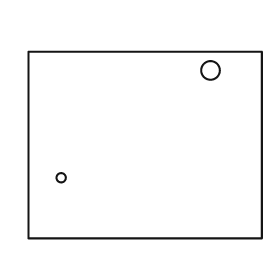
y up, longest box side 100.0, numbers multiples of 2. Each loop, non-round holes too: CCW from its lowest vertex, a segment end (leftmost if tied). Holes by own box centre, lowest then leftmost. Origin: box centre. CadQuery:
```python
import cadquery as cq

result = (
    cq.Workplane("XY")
    .moveTo(-50.0, -40.0)
    .lineTo(50.0, -40.0)
    .lineTo(50.0, 40.0)
    .lineTo(-50.0, 40.0)
    .close()
    .moveTo(-36.0, -14.0)
    .circle(2.0)
    .moveTo(28.0, 32.0)
    .circle(4.0)
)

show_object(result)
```